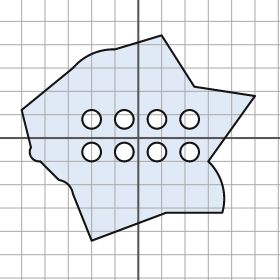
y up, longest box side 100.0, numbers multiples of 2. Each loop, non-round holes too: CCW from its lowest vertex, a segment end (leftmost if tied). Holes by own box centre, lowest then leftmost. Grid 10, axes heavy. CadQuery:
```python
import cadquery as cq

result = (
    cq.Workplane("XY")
    .moveTo(-20.0, -44.0)
    .lineTo(12.0, -32.0)
    .lineTo(36.0, -32.0)
    .threePointArc((36.0, -20.0), (30.0, -10.0))
    .lineTo(50.0, 18.0)
    .lineTo(24.0, 22.0)
    .lineTo(10.0, 44.0)
    .lineTo(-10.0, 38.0)
    .threePointArc((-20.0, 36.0), (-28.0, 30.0))
    .lineTo(-50.0, 12.0)
    .lineTo(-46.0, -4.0)
    .threePointArc((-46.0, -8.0), (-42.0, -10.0))
    .lineTo(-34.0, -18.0)
    .threePointArc((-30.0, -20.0), (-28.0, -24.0))
    .close()
    .moveTo(-20.0, -6.0)
    .circle(4.0)
    .moveTo(-6.0, -6.0)
    .circle(4.0)
    .moveTo(8.0, -6.0)
    .circle(4.0)
    .moveTo(22.0, -6.0)
    .circle(4.0)
    .moveTo(-20.0, 8.0)
    .circle(4.0)
    .moveTo(-6.0, 8.0)
    .circle(4.0)
    .moveTo(8.0, 8.0)
    .circle(4.0)
    .moveTo(22.0, 8.0)
    .circle(4.0)
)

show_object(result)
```